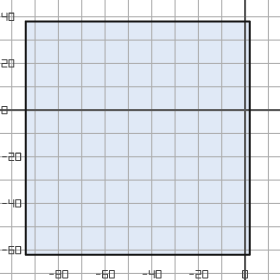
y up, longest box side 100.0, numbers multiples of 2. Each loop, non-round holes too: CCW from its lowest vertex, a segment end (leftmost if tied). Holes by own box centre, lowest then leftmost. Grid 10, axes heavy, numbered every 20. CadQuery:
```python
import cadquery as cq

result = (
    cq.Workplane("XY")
    .moveTo(-94.0, -62.0)
    .lineTo(2.0, -62.0)
    .lineTo(2.0, 38.0)
    .lineTo(-94.0, 38.0)
    .close()
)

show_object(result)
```